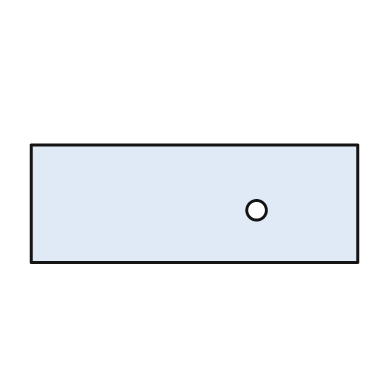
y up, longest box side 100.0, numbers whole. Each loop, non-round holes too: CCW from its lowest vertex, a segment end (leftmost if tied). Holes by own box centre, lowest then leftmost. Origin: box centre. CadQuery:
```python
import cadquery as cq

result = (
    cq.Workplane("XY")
    .moveTo(-50.0, -18.0)
    .lineTo(50.0, -18.0)
    .lineTo(50.0, 18.0)
    .lineTo(-50.0, 18.0)
    .close()
    .moveTo(19.0, -2.0)
    .circle(3.0)
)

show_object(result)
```